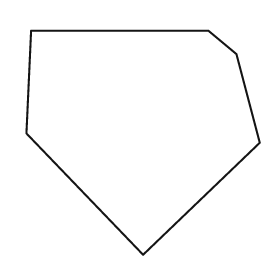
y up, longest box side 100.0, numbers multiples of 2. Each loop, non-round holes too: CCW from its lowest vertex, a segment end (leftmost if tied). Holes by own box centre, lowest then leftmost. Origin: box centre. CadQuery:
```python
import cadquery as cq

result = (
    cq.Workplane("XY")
    .moveTo(0.0, -48.0)
    .lineTo(50.0, 0.0)
    .lineTo(40.0, 38.0)
    .lineTo(28.0, 48.0)
    .lineTo(-48.0, 48.0)
    .lineTo(-50.0, 4.0)
    .close()
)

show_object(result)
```